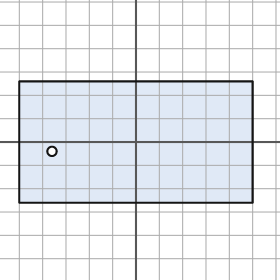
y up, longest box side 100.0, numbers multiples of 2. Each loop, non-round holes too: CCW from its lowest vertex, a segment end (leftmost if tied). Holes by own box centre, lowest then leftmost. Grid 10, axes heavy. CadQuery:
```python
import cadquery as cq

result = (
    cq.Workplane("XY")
    .moveTo(-50.0, -26.0)
    .lineTo(50.0, -26.0)
    .lineTo(50.0, 26.0)
    .lineTo(-50.0, 26.0)
    .close()
    .moveTo(-36.0, -4.0)
    .circle(2.0)
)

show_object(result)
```